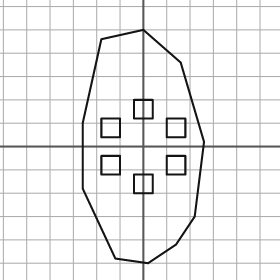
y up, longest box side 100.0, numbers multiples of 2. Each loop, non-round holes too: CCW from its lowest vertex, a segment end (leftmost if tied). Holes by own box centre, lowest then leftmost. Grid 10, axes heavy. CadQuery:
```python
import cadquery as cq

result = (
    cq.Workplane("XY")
    .moveTo(2.0, -50.0)
    .lineTo(14.0, -42.0)
    .lineTo(22.0, -30.0)
    .lineTo(26.0, 2.0)
    .lineTo(16.0, 36.0)
    .lineTo(0.0, 50.0)
    .lineTo(-18.0, 46.0)
    .lineTo(-26.0, 10.0)
    .lineTo(-26.0, -18.0)
    .lineTo(-12.0, -48.0)
    .close()
    .moveTo(-4.0, -20.0)
    .lineTo(4.0, -20.0)
    .lineTo(4.0, -12.0)
    .lineTo(-4.0, -12.0)
    .close()
    .moveTo(-18.0, -12.0)
    .lineTo(-10.0, -12.0)
    .lineTo(-10.0, -4.0)
    .lineTo(-18.0, -4.0)
    .close()
    .moveTo(10.0, -12.0)
    .lineTo(18.0, -12.0)
    .lineTo(18.0, -4.0)
    .lineTo(10.0, -4.0)
    .close()
    .moveTo(-18.0, 4.0)
    .lineTo(-10.0, 4.0)
    .lineTo(-10.0, 12.0)
    .lineTo(-18.0, 12.0)
    .close()
    .moveTo(10.0, 4.0)
    .lineTo(18.0, 4.0)
    .lineTo(18.0, 12.0)
    .lineTo(10.0, 12.0)
    .close()
    .moveTo(-4.0, 12.0)
    .lineTo(4.0, 12.0)
    .lineTo(4.0, 20.0)
    .lineTo(-4.0, 20.0)
    .close()
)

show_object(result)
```